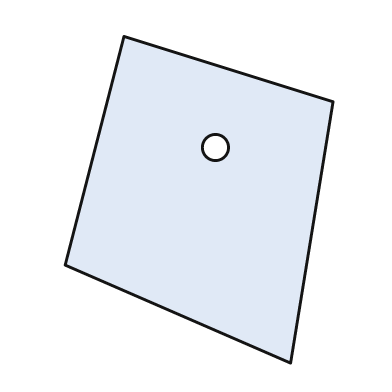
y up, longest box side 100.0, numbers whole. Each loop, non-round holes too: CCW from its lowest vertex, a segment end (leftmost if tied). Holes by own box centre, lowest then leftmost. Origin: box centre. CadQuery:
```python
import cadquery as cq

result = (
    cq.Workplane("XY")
    .moveTo(28.0, -50.0)
    .lineTo(41.0, 30.0)
    .lineTo(-23.0, 50.0)
    .lineTo(-41.0, -20.0)
    .close()
    .moveTo(5.0, 16.0)
    .circle(4.0)
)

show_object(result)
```